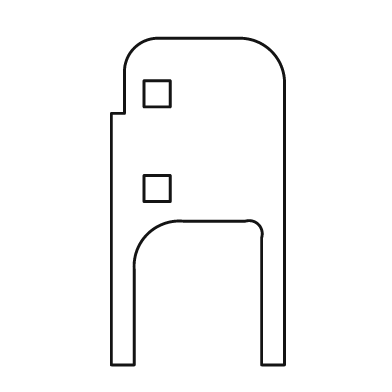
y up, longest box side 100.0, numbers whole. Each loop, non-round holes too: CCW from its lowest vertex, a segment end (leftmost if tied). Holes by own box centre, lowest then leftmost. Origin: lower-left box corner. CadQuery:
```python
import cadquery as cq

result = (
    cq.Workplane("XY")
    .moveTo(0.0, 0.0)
    .lineTo(7.0, 0.0)
    .lineTo(7.0, 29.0)
    .threePointArc((11.0, 40.0), (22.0, 44.0))
    .lineTo(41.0, 44.0)
    .threePointArc((45.0, 43.0), (46.0, 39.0))
    .lineTo(46.0, 0.0)
    .lineTo(53.0, 0.0)
    .lineTo(53.0, 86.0)
    .threePointArc((49.0, 96.0), (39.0, 100.0))
    .lineTo(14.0, 100.0)
    .threePointArc((7.0, 97.0), (4.0, 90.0))
    .lineTo(4.0, 77.0)
    .lineTo(0.0, 77.0)
    .close()
    .moveTo(10.0, 50.0)
    .lineTo(18.0, 50.0)
    .lineTo(18.0, 58.0)
    .lineTo(10.0, 58.0)
    .close()
    .moveTo(10.0, 79.0)
    .lineTo(18.0, 79.0)
    .lineTo(18.0, 87.0)
    .lineTo(10.0, 87.0)
    .close()
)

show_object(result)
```